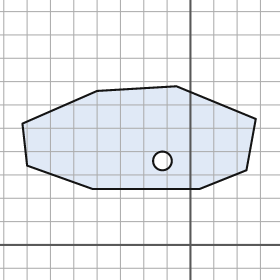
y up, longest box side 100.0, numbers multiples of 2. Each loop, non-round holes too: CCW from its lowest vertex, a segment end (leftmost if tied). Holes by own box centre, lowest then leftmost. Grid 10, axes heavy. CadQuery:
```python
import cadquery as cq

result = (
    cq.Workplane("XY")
    .moveTo(-42.0, 24.0)
    .lineTo(4.0, 24.0)
    .lineTo(24.0, 32.0)
    .lineTo(28.0, 54.0)
    .lineTo(-6.0, 68.0)
    .lineTo(-40.0, 66.0)
    .lineTo(-72.0, 52.0)
    .lineTo(-70.0, 34.0)
    .close()
    .moveTo(-12.0, 36.0)
    .circle(4.0)
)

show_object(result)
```